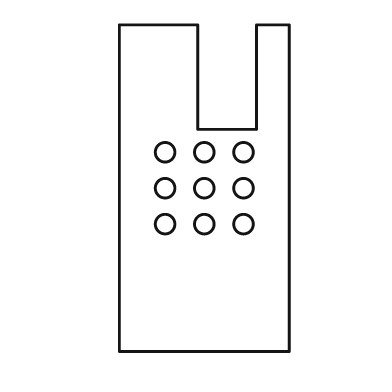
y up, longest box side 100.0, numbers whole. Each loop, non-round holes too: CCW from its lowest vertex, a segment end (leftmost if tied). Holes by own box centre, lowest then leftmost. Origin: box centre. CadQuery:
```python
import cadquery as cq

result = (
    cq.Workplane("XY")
    .moveTo(-26.0, -50.0)
    .lineTo(26.0, -50.0)
    .lineTo(26.0, 50.0)
    .lineTo(16.0, 50.0)
    .lineTo(16.0, 18.0)
    .lineTo(-2.0, 18.0)
    .lineTo(-2.0, 50.0)
    .lineTo(-26.0, 50.0)
    .close()
    .moveTo(-12.0, -11.0)
    .circle(3.0)
    .moveTo(0.0, -11.0)
    .circle(3.0)
    .moveTo(12.0, -11.0)
    .circle(3.0)
    .moveTo(-12.0, 0.0)
    .circle(3.0)
    .moveTo(0.0, 0.0)
    .circle(3.0)
    .moveTo(12.0, 0.0)
    .circle(3.0)
    .moveTo(-12.0, 11.0)
    .circle(3.0)
    .moveTo(0.0, 11.0)
    .circle(3.0)
    .moveTo(12.0, 11.0)
    .circle(3.0)
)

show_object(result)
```